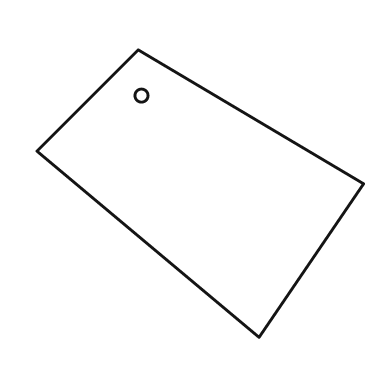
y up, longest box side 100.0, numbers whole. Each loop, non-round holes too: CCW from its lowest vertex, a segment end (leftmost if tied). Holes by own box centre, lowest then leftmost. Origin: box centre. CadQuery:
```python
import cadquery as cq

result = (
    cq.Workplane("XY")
    .moveTo(18.0, -44.0)
    .lineTo(50.0, 3.0)
    .lineTo(-19.0, 44.0)
    .lineTo(-50.0, 13.0)
    .close()
    .moveTo(-18.0, 30.0)
    .circle(2.0)
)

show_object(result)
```